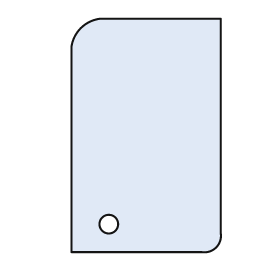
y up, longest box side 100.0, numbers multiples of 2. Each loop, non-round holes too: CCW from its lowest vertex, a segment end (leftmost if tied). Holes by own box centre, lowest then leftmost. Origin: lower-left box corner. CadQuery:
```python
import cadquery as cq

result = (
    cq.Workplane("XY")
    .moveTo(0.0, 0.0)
    .lineTo(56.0, 0.0)
    .threePointArc((62.0, 2.0), (64.0, 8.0))
    .lineTo(64.0, 100.0)
    .lineTo(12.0, 100.0)
    .threePointArc((4.0, 96.0), (0.0, 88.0))
    .close()
    .moveTo(16.0, 12.0)
    .circle(4.0)
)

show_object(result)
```